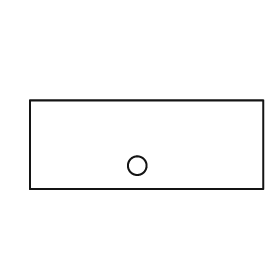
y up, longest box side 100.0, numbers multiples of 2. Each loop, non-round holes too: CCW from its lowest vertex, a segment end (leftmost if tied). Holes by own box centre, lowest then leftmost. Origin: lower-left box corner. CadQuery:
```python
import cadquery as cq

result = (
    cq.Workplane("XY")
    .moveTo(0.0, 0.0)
    .lineTo(100.0, 0.0)
    .lineTo(100.0, 38.0)
    .lineTo(0.0, 38.0)
    .close()
    .moveTo(46.0, 10.0)
    .circle(4.0)
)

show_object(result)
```